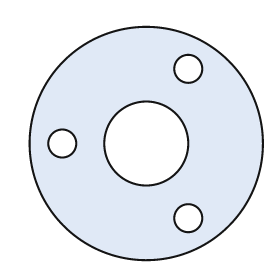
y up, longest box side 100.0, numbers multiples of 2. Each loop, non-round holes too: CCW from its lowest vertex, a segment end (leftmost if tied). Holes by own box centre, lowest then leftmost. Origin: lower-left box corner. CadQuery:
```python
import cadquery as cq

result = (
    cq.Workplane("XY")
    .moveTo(50.0, 50.0)
    .circle(50.0)
    .moveTo(68.0, 18.0)
    .circle(6.0)
    .moveTo(14.0, 50.0)
    .circle(6.0)
    .moveTo(50.0, 50.0)
    .circle(18.0)
    .moveTo(68.0, 82.0)
    .circle(6.0)
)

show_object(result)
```